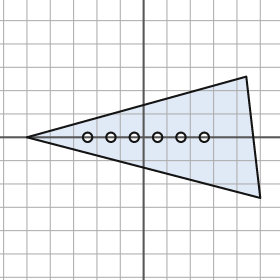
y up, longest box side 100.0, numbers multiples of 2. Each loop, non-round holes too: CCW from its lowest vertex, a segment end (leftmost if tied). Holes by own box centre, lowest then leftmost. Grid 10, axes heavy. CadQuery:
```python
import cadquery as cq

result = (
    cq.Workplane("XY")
    .moveTo(50.0, -26.0)
    .lineTo(44.0, 26.0)
    .lineTo(-50.0, 0.0)
    .close()
    .moveTo(-24.0, 0.0)
    .circle(2.0)
    .moveTo(-14.0, 0.0)
    .circle(2.0)
    .moveTo(-4.0, 0.0)
    .circle(2.0)
    .moveTo(6.0, 0.0)
    .circle(2.0)
    .moveTo(16.0, 0.0)
    .circle(2.0)
    .moveTo(26.0, 0.0)
    .circle(2.0)
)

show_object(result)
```